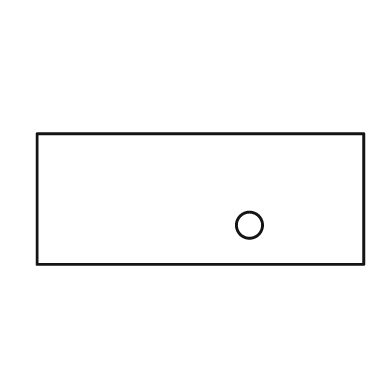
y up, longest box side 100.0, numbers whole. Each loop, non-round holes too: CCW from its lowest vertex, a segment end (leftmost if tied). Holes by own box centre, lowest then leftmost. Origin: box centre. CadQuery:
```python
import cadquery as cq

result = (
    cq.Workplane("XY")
    .moveTo(-50.0, -20.0)
    .lineTo(50.0, -20.0)
    .lineTo(50.0, 20.0)
    .lineTo(-50.0, 20.0)
    .close()
    .moveTo(15.0, -8.0)
    .circle(4.0)
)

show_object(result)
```